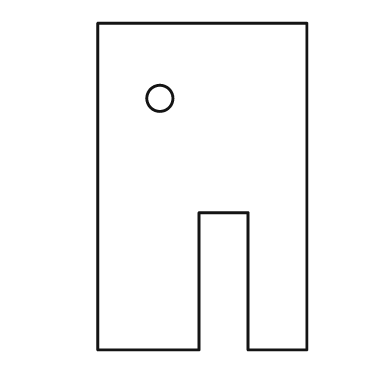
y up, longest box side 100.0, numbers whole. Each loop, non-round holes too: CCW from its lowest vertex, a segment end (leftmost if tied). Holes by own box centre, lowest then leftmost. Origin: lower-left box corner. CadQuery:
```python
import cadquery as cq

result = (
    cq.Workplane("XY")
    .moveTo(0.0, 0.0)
    .lineTo(31.0, 0.0)
    .lineTo(31.0, 42.0)
    .lineTo(46.0, 42.0)
    .lineTo(46.0, 0.0)
    .lineTo(64.0, 0.0)
    .lineTo(64.0, 100.0)
    .lineTo(0.0, 100.0)
    .close()
    .moveTo(19.0, 77.0)
    .circle(4.0)
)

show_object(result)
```